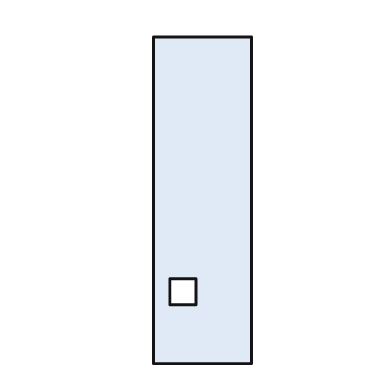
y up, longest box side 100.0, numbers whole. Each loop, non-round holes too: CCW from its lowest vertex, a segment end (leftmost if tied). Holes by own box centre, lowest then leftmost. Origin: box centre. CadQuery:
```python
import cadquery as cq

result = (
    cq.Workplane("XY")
    .moveTo(-15.0, -50.0)
    .lineTo(15.0, -50.0)
    .lineTo(15.0, 50.0)
    .lineTo(-15.0, 50.0)
    .close()
    .moveTo(-10.0, -32.0)
    .lineTo(-2.0, -32.0)
    .lineTo(-2.0, -24.0)
    .lineTo(-10.0, -24.0)
    .close()
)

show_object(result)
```